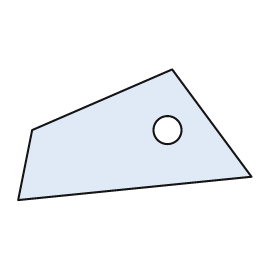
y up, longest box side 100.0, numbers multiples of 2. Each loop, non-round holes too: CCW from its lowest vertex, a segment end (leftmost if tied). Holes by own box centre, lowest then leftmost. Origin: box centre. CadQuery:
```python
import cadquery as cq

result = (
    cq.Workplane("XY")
    .moveTo(-50.0, -28.0)
    .lineTo(50.0, -18.0)
    .lineTo(16.0, 28.0)
    .lineTo(-44.0, 2.0)
    .close()
    .moveTo(14.0, 2.0)
    .circle(6.0)
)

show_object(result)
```